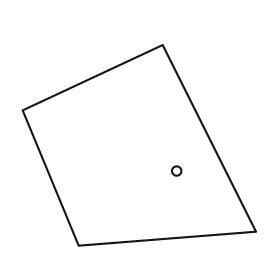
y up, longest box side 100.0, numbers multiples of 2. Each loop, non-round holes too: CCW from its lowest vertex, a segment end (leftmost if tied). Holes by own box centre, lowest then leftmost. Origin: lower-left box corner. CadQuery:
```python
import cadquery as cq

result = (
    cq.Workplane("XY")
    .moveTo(24.0, 0.0)
    .lineTo(100.0, 6.0)
    .lineTo(60.0, 86.0)
    .lineTo(0.0, 58.0)
    .close()
    .moveTo(66.0, 32.0)
    .circle(2.0)
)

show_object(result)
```